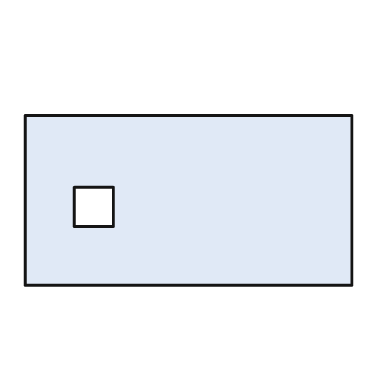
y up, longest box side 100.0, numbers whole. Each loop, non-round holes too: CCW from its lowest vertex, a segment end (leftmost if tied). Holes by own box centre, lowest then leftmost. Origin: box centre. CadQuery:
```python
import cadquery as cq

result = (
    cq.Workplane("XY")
    .moveTo(-50.0, -26.0)
    .lineTo(50.0, -26.0)
    .lineTo(50.0, 26.0)
    .lineTo(-50.0, 26.0)
    .close()
    .moveTo(-35.0, -8.0)
    .lineTo(-23.0, -8.0)
    .lineTo(-23.0, 4.0)
    .lineTo(-35.0, 4.0)
    .close()
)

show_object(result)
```